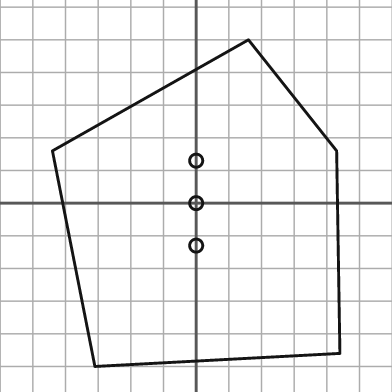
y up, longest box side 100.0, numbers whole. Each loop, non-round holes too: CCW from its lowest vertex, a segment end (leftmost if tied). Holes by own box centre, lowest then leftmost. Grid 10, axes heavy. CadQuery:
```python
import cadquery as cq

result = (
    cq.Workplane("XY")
    .moveTo(-31.0, -50.0)
    .lineTo(44.0, -46.0)
    .lineTo(43.0, 16.0)
    .lineTo(16.0, 50.0)
    .lineTo(-44.0, 16.0)
    .close()
    .moveTo(0.0, -13.0)
    .circle(2.0)
    .moveTo(0.0, 0.0)
    .circle(2.0)
    .moveTo(0.0, 13.0)
    .circle(2.0)
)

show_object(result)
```